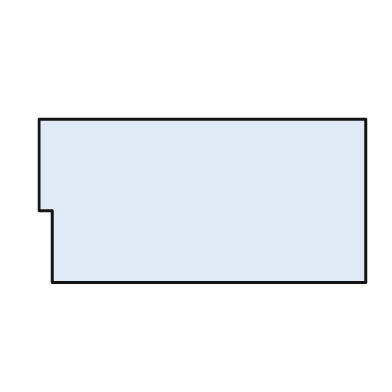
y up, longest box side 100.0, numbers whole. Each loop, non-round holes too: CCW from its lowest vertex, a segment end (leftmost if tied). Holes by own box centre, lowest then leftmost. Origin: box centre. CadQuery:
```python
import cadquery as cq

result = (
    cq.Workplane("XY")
    .moveTo(-46.0, -25.0)
    .lineTo(50.0, -25.0)
    .lineTo(50.0, 25.0)
    .lineTo(-50.0, 25.0)
    .lineTo(-50.0, -3.0)
    .lineTo(-46.0, -3.0)
    .close()
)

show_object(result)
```